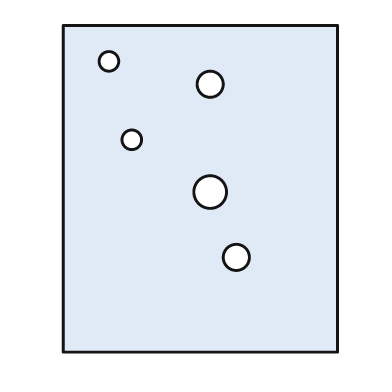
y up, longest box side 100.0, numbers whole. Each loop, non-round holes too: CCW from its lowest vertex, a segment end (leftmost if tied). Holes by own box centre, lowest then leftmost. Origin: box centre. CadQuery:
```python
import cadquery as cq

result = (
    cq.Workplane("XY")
    .moveTo(-42.0, -50.0)
    .lineTo(42.0, -50.0)
    .lineTo(42.0, 50.0)
    .lineTo(-42.0, 50.0)
    .close()
    .moveTo(11.0, -21.0)
    .circle(4.0)
    .moveTo(3.0, -1.0)
    .circle(5.0)
    .moveTo(-21.0, 15.0)
    .circle(3.0)
    .moveTo(3.0, 32.0)
    .circle(4.0)
    .moveTo(-28.0, 39.0)
    .circle(3.0)
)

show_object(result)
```